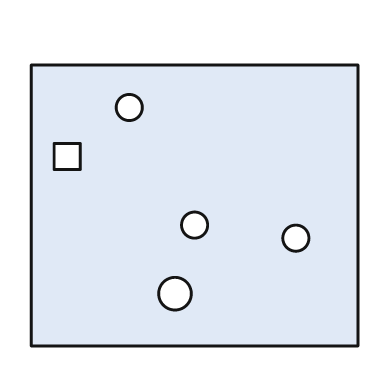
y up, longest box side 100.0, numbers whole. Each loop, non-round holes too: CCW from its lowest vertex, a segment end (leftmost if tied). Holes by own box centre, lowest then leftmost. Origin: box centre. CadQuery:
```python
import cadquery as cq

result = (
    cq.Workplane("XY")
    .moveTo(-50.0, -43.0)
    .lineTo(50.0, -43.0)
    .lineTo(50.0, 43.0)
    .lineTo(-50.0, 43.0)
    .close()
    .moveTo(-6.0, -27.0)
    .circle(5.0)
    .moveTo(31.0, -10.0)
    .circle(4.0)
    .moveTo(0.0, -6.0)
    .circle(4.0)
    .moveTo(-43.0, 11.0)
    .lineTo(-35.0, 11.0)
    .lineTo(-35.0, 19.0)
    .lineTo(-43.0, 19.0)
    .close()
    .moveTo(-20.0, 30.0)
    .circle(4.0)
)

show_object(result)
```